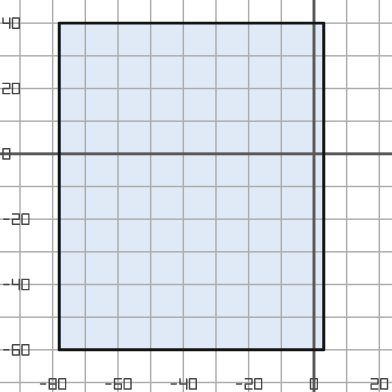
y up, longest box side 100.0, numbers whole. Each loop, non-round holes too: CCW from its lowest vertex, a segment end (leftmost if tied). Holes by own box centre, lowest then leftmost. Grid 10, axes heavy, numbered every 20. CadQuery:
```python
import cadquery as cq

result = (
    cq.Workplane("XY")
    .moveTo(-78.0, -60.0)
    .lineTo(3.0, -60.0)
    .lineTo(3.0, 40.0)
    .lineTo(-78.0, 40.0)
    .close()
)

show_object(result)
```